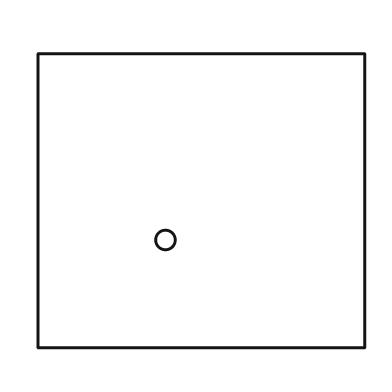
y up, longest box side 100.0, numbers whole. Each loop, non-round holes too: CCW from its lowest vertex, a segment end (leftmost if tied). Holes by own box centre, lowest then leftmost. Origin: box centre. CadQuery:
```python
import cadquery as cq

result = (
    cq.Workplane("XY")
    .moveTo(-50.0, -45.0)
    .lineTo(50.0, -45.0)
    .lineTo(50.0, 45.0)
    .lineTo(-50.0, 45.0)
    .close()
    .moveTo(-11.0, -12.0)
    .circle(3.0)
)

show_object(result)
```